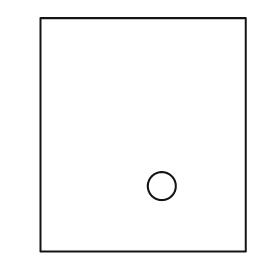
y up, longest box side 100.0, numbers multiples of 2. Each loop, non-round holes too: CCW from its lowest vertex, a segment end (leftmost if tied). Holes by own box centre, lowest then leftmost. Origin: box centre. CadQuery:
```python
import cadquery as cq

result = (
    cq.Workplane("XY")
    .moveTo(-44.0, -50.0)
    .lineTo(44.0, -50.0)
    .lineTo(44.0, 50.0)
    .lineTo(-44.0, 50.0)
    .close()
    .moveTo(8.0, -22.0)
    .circle(6.0)
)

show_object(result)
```